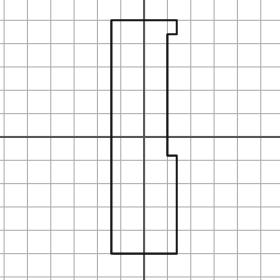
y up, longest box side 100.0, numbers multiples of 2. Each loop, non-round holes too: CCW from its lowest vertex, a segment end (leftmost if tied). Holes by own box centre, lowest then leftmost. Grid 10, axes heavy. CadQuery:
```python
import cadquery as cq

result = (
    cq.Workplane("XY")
    .moveTo(-14.0, -50.0)
    .lineTo(14.0, -50.0)
    .lineTo(14.0, -8.0)
    .lineTo(10.0, -8.0)
    .lineTo(10.0, 44.0)
    .lineTo(14.0, 44.0)
    .lineTo(14.0, 50.0)
    .lineTo(-14.0, 50.0)
    .close()
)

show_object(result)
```